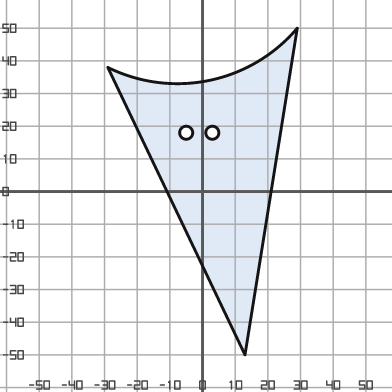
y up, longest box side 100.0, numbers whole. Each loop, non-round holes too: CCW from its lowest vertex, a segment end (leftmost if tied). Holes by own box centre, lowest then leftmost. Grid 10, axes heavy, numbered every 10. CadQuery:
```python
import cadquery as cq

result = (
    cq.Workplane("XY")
    .moveTo(13.0, -50.0)
    .lineTo(29.0, 50.0)
    .threePointArc((2.0, 34.0), (-29.0, 38.0))
    .close()
    .moveTo(-5.0, 18.0)
    .circle(2.0)
    .moveTo(3.0, 18.0)
    .circle(2.0)
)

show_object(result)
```